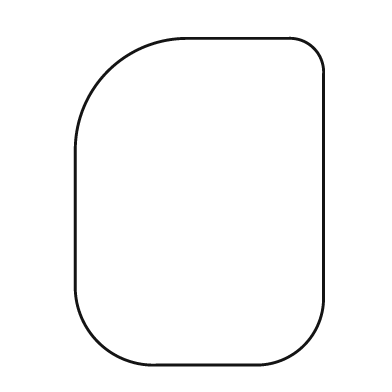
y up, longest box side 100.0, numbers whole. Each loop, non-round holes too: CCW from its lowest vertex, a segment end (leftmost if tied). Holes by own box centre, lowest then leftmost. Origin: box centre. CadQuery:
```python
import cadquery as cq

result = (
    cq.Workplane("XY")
    .moveTo(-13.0, -50.0)
    .lineTo(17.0, -50.0)
    .threePointArc((32.0, -44.0), (38.0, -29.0))
    .lineTo(38.0, 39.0)
    .threePointArc((35.0, 47.0), (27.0, 50.0))
    .lineTo(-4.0, 50.0)
    .threePointArc((-28.0, 40.0), (-38.0, 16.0))
    .lineTo(-38.0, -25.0)
    .threePointArc((-31.0, -43.0), (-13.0, -50.0))
    .close()
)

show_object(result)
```